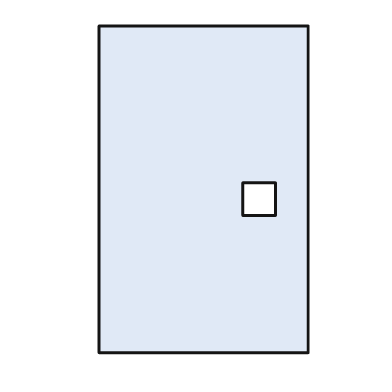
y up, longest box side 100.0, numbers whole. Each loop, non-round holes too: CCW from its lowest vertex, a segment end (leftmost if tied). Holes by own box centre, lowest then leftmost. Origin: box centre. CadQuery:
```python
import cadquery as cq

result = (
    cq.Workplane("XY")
    .moveTo(-32.0, -50.0)
    .lineTo(32.0, -50.0)
    .lineTo(32.0, 50.0)
    .lineTo(-32.0, 50.0)
    .close()
    .moveTo(12.0, -8.0)
    .lineTo(22.0, -8.0)
    .lineTo(22.0, 2.0)
    .lineTo(12.0, 2.0)
    .close()
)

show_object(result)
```